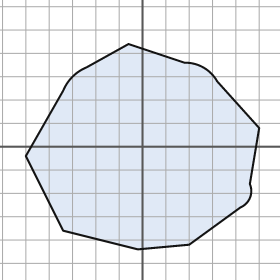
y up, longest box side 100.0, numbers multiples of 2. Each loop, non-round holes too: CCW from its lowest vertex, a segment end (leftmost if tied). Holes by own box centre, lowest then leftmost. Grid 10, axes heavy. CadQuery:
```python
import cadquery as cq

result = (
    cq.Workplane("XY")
    .moveTo(-2.0, -44.0)
    .lineTo(20.0, -42.0)
    .lineTo(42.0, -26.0)
    .threePointArc((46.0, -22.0), (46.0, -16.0))
    .lineTo(50.0, 8.0)
    .lineTo(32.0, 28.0)
    .threePointArc((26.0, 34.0), (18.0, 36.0))
    .lineTo(-6.0, 44.0)
    .lineTo(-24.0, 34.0)
    .threePointArc((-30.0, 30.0), (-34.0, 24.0))
    .lineTo(-50.0, -4.0)
    .lineTo(-34.0, -36.0)
    .close()
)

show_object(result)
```